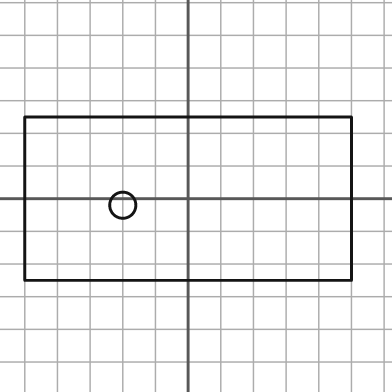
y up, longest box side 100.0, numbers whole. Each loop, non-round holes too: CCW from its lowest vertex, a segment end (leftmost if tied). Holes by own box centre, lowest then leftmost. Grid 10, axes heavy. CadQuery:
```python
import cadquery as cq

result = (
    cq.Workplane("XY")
    .moveTo(-50.0, -25.0)
    .lineTo(50.0, -25.0)
    .lineTo(50.0, 25.0)
    .lineTo(-50.0, 25.0)
    .close()
    .moveTo(-20.0, -2.0)
    .circle(4.0)
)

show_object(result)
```